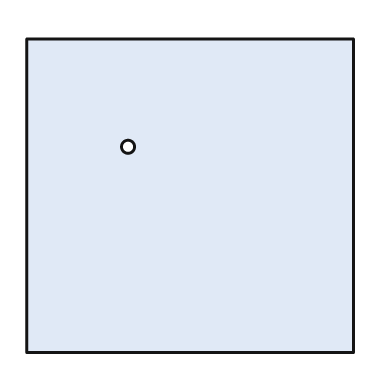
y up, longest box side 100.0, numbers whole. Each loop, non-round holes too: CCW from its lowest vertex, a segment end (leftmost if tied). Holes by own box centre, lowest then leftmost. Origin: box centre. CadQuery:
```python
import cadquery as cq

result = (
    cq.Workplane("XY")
    .moveTo(-50.0, -48.0)
    .lineTo(50.0, -48.0)
    .lineTo(50.0, 48.0)
    .lineTo(-50.0, 48.0)
    .close()
    .moveTo(-19.0, 15.0)
    .circle(2.0)
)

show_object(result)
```